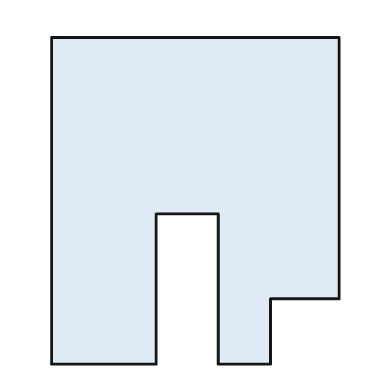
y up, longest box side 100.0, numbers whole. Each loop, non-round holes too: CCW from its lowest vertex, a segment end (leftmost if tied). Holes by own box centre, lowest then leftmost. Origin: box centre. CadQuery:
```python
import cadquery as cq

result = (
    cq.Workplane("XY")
    .moveTo(-44.0, -50.0)
    .lineTo(-12.0, -50.0)
    .lineTo(-12.0, -4.0)
    .lineTo(7.0, -4.0)
    .lineTo(7.0, -50.0)
    .lineTo(23.0, -50.0)
    .lineTo(23.0, -30.0)
    .lineTo(44.0, -30.0)
    .lineTo(44.0, 50.0)
    .lineTo(-44.0, 50.0)
    .close()
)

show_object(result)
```